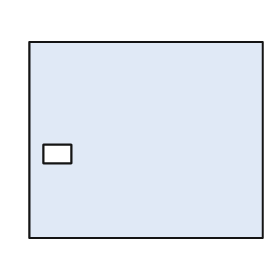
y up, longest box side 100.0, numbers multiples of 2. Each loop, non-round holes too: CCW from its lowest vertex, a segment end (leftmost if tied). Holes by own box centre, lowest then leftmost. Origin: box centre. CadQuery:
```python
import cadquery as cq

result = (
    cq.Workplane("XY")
    .moveTo(-50.0, -42.0)
    .lineTo(50.0, -42.0)
    .lineTo(50.0, 42.0)
    .lineTo(-50.0, 42.0)
    .close()
    .moveTo(-44.0, -10.0)
    .lineTo(-32.0, -10.0)
    .lineTo(-32.0, -2.0)
    .lineTo(-44.0, -2.0)
    .close()
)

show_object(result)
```